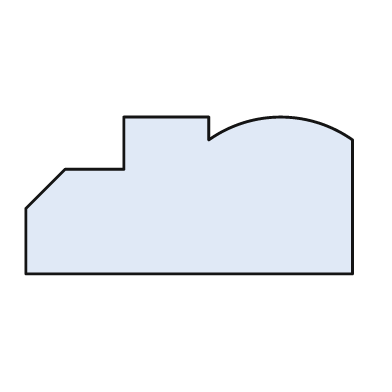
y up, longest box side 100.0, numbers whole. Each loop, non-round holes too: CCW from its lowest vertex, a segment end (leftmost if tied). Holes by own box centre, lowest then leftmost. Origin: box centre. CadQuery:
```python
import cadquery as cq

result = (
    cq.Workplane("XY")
    .moveTo(-50.0, -24.0)
    .lineTo(50.0, -24.0)
    .lineTo(50.0, 17.0)
    .threePointArc((28.0, 24.0), (6.0, 17.0))
    .lineTo(6.0, 24.0)
    .lineTo(-20.0, 24.0)
    .lineTo(-20.0, 8.0)
    .lineTo(-38.0, 8.0)
    .lineTo(-50.0, -4.0)
    .close()
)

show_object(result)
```